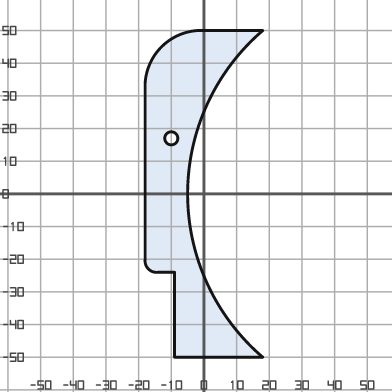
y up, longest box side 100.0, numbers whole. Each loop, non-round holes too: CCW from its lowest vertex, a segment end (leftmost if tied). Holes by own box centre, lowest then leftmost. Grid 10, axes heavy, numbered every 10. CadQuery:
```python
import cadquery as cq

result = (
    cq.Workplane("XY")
    .moveTo(-9.0, -50.0)
    .lineTo(18.0, -50.0)
    .threePointArc((-5.0, 0.0), (18.0, 50.0))
    .lineTo(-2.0, 50.0)
    .threePointArc((-13.0, 45.0), (-18.0, 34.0))
    .lineTo(-18.0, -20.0)
    .threePointArc((-17.0, -23.0), (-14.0, -24.0))
    .lineTo(-9.0, -24.0)
    .close()
    .moveTo(-10.0, 17.0)
    .circle(2.0)
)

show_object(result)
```